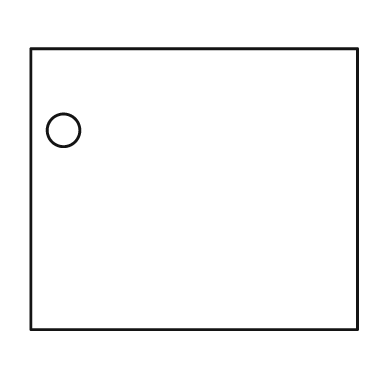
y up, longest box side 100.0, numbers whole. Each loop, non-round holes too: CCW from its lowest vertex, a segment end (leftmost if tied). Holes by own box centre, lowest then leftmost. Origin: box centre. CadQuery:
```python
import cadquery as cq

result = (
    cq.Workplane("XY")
    .moveTo(-50.0, -43.0)
    .lineTo(50.0, -43.0)
    .lineTo(50.0, 43.0)
    .lineTo(-50.0, 43.0)
    .close()
    .moveTo(-40.0, 18.0)
    .circle(5.0)
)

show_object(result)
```